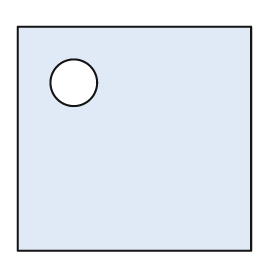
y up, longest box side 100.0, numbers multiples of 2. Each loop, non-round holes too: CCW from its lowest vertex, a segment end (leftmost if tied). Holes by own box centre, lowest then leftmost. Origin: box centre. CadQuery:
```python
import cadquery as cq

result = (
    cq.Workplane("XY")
    .moveTo(-50.0, -48.0)
    .lineTo(50.0, -48.0)
    .lineTo(50.0, 48.0)
    .lineTo(-50.0, 48.0)
    .close()
    .moveTo(-26.0, 24.0)
    .circle(10.0)
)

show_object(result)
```